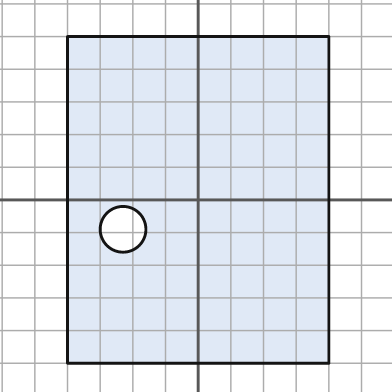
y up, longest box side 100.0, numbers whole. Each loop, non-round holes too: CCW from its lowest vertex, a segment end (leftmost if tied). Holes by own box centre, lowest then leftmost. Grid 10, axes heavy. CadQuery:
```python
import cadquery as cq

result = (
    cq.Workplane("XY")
    .moveTo(-40.0, -50.0)
    .lineTo(40.0, -50.0)
    .lineTo(40.0, 50.0)
    .lineTo(-40.0, 50.0)
    .close()
    .moveTo(-23.0, -9.0)
    .circle(7.0)
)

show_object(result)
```